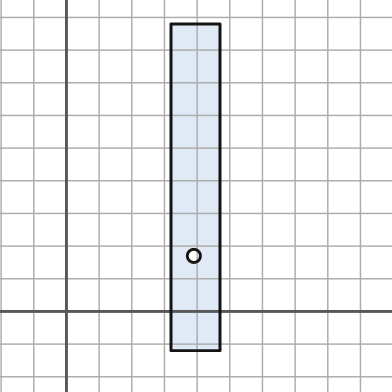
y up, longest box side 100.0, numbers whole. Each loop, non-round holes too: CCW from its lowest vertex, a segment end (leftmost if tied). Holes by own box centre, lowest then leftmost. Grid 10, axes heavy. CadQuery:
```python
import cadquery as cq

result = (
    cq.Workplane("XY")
    .moveTo(32.0, -12.0)
    .lineTo(47.0, -12.0)
    .lineTo(47.0, 88.0)
    .lineTo(32.0, 88.0)
    .close()
    .moveTo(39.0, 17.0)
    .circle(2.0)
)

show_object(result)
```